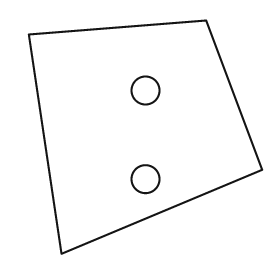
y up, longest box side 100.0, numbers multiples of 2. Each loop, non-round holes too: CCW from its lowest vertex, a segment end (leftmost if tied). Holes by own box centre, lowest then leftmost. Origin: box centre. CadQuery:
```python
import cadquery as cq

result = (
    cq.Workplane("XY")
    .moveTo(-36.0, -50.0)
    .lineTo(50.0, -14.0)
    .lineTo(26.0, 50.0)
    .lineTo(-50.0, 44.0)
    .close()
    .moveTo(0.0, -18.0)
    .circle(6.0)
    .moveTo(0.0, 20.0)
    .circle(6.0)
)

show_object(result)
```